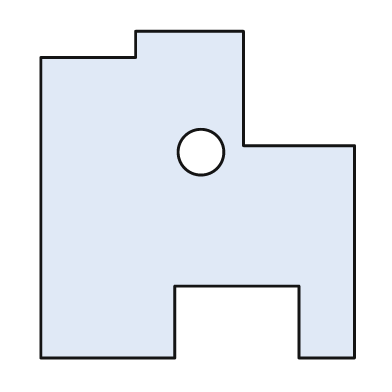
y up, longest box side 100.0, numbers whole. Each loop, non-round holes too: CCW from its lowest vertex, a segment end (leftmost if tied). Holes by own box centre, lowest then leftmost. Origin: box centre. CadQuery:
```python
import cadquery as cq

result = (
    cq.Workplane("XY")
    .moveTo(-48.0, -50.0)
    .lineTo(-7.0, -50.0)
    .lineTo(-7.0, -28.0)
    .lineTo(31.0, -28.0)
    .lineTo(31.0, -50.0)
    .lineTo(48.0, -50.0)
    .lineTo(48.0, 15.0)
    .lineTo(14.0, 15.0)
    .lineTo(14.0, 50.0)
    .lineTo(-19.0, 50.0)
    .lineTo(-19.0, 42.0)
    .lineTo(-48.0, 42.0)
    .close()
    .moveTo(1.0, 13.0)
    .circle(7.0)
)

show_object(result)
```